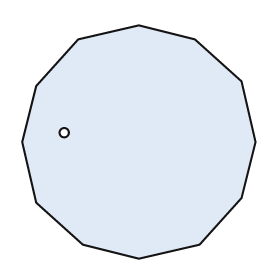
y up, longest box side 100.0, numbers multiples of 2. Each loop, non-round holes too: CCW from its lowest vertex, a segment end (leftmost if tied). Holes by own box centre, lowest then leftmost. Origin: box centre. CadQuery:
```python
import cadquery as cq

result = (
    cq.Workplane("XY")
    .moveTo(0.0, -50.0)
    .lineTo(26.0, -44.0)
    .lineTo(44.0, -24.0)
    .lineTo(50.0, 0.0)
    .lineTo(44.0, 26.0)
    .lineTo(24.0, 44.0)
    .lineTo(0.0, 50.0)
    .lineTo(-26.0, 44.0)
    .lineTo(-44.0, 24.0)
    .lineTo(-50.0, 0.0)
    .lineTo(-44.0, -26.0)
    .lineTo(-24.0, -44.0)
    .close()
    .moveTo(-32.0, 4.0)
    .circle(2.0)
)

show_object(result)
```